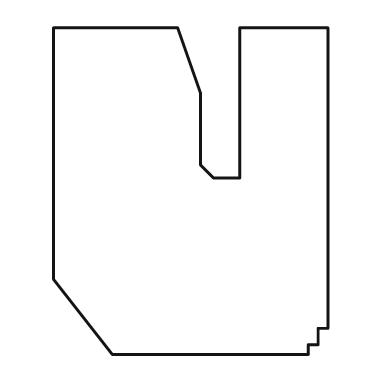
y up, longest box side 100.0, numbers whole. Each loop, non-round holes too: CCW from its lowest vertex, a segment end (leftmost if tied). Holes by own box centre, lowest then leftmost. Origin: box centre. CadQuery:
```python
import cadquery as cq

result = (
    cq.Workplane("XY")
    .moveTo(-24.0, -50.0)
    .lineTo(36.0, -50.0)
    .lineTo(36.0, -47.0)
    .lineTo(39.0, -47.0)
    .lineTo(39.0, -42.0)
    .lineTo(42.0, -42.0)
    .lineTo(42.0, 50.0)
    .lineTo(15.0, 50.0)
    .lineTo(15.0, 4.0)
    .lineTo(7.0, 4.0)
    .lineTo(3.0, 8.0)
    .lineTo(3.0, 30.0)
    .lineTo(-4.0, 50.0)
    .lineTo(-42.0, 50.0)
    .lineTo(-42.0, -27.0)
    .close()
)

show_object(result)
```